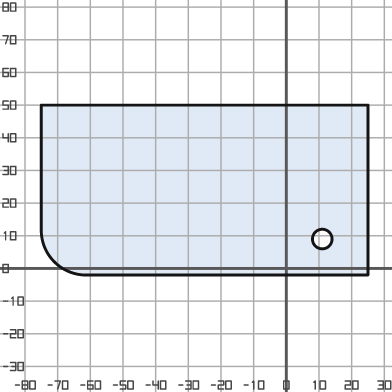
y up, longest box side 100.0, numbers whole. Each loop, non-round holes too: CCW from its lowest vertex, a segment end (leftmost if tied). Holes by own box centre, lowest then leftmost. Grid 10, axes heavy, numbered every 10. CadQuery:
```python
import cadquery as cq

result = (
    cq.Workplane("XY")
    .moveTo(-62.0, -2.0)
    .lineTo(25.0, -2.0)
    .lineTo(25.0, 50.0)
    .lineTo(-75.0, 50.0)
    .lineTo(-75.0, 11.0)
    .threePointArc((-71.0, 2.0), (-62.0, -2.0))
    .close()
    .moveTo(11.0, 9.0)
    .circle(3.0)
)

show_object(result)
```